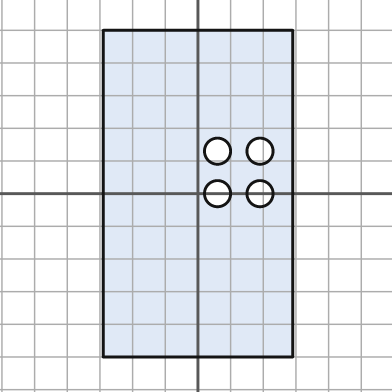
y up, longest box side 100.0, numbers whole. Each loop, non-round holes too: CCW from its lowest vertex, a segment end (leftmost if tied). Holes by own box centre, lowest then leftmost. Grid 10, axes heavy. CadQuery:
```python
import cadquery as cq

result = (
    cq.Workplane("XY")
    .moveTo(-29.0, -50.0)
    .lineTo(29.0, -50.0)
    .lineTo(29.0, 50.0)
    .lineTo(-29.0, 50.0)
    .close()
    .moveTo(6.0, 0.0)
    .circle(4.0)
    .moveTo(19.0, 0.0)
    .circle(4.0)
    .moveTo(6.0, 13.0)
    .circle(4.0)
    .moveTo(19.0, 13.0)
    .circle(4.0)
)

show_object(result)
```